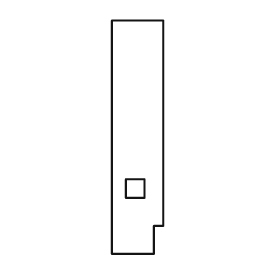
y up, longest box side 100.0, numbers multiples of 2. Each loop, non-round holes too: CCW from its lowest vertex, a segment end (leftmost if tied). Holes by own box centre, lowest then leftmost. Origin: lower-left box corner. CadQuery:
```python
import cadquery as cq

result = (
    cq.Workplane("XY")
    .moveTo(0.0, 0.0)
    .lineTo(18.0, 0.0)
    .lineTo(18.0, 12.0)
    .lineTo(22.0, 12.0)
    .lineTo(22.0, 100.0)
    .lineTo(0.0, 100.0)
    .close()
    .moveTo(6.0, 24.0)
    .lineTo(14.0, 24.0)
    .lineTo(14.0, 32.0)
    .lineTo(6.0, 32.0)
    .close()
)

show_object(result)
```